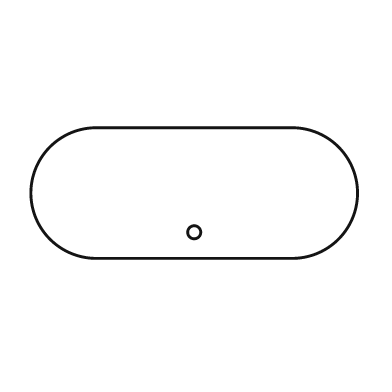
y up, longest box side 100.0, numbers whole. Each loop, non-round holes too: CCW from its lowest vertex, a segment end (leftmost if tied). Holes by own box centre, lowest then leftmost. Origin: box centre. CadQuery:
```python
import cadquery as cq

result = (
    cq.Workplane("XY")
    .moveTo(-30.0, -20.0)
    .lineTo(30.0, -20.0)
    .threePointArc((50.0, 0.0), (30.0, 20.0))
    .lineTo(-30.0, 20.0)
    .threePointArc((-50.0, 0.0), (-30.0, -20.0))
    .close()
    .moveTo(0.0, -12.0)
    .circle(2.0)
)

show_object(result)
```